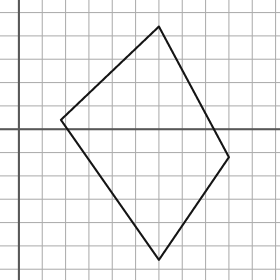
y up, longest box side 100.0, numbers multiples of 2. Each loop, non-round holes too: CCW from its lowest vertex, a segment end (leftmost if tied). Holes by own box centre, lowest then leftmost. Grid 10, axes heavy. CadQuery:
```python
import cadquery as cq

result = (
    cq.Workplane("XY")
    .moveTo(60.0, -56.0)
    .lineTo(90.0, -12.0)
    .lineTo(60.0, 44.0)
    .lineTo(18.0, 4.0)
    .close()
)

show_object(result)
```